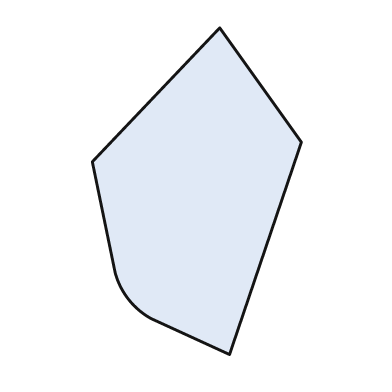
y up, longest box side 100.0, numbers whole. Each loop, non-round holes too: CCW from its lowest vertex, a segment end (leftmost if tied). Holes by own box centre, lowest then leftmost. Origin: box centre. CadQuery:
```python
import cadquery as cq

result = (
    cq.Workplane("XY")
    .moveTo(10.0, -50.0)
    .lineTo(32.0, 15.0)
    .lineTo(7.0, 50.0)
    .lineTo(-32.0, 9.0)
    .lineTo(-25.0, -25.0)
    .threePointArc((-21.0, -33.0), (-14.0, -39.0))
    .close()
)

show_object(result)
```